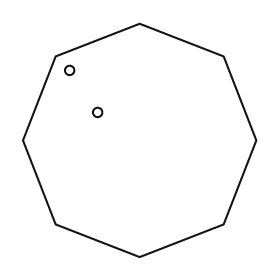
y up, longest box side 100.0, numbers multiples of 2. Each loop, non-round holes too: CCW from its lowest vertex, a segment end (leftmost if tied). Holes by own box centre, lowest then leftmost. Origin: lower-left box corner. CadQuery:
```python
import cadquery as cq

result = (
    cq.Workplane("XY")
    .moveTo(50.0, 0.0)
    .lineTo(86.0, 14.0)
    .lineTo(100.0, 50.0)
    .lineTo(86.0, 86.0)
    .lineTo(50.0, 100.0)
    .lineTo(14.0, 86.0)
    .lineTo(0.0, 50.0)
    .lineTo(14.0, 14.0)
    .close()
    .moveTo(32.0, 62.0)
    .circle(2.0)
    .moveTo(20.0, 80.0)
    .circle(2.0)
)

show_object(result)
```